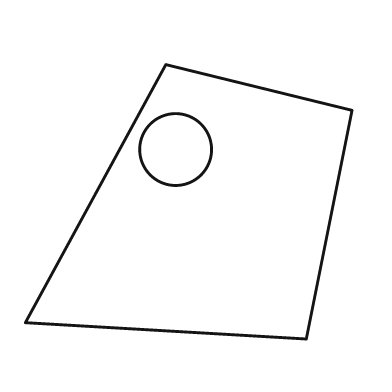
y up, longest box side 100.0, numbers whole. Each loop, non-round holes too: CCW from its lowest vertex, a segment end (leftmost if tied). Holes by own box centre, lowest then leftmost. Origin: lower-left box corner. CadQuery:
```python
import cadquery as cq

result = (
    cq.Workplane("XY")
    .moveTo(86.0, 0.0)
    .lineTo(100.0, 70.0)
    .lineTo(43.0, 84.0)
    .lineTo(0.0, 5.0)
    .close()
    .moveTo(46.0, 58.0)
    .circle(11.0)
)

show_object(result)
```